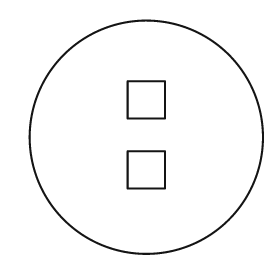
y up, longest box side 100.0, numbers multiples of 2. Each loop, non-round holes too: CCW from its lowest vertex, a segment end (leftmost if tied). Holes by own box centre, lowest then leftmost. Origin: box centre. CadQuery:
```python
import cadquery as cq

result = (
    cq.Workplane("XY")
    .moveTo(0.0, 0.0)
    .circle(50.0)
    .moveTo(-8.0, -22.0)
    .lineTo(8.0, -22.0)
    .lineTo(8.0, -6.0)
    .lineTo(-8.0, -6.0)
    .close()
    .moveTo(-8.0, 8.0)
    .lineTo(8.0, 8.0)
    .lineTo(8.0, 24.0)
    .lineTo(-8.0, 24.0)
    .close()
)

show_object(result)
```